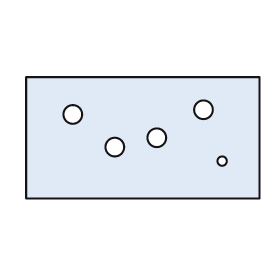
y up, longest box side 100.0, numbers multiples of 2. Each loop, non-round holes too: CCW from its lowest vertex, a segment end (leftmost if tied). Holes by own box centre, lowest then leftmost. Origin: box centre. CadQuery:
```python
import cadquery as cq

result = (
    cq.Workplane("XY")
    .moveTo(-50.0, -26.0)
    .lineTo(50.0, -26.0)
    .lineTo(50.0, 26.0)
    .lineTo(-50.0, 26.0)
    .close()
    .moveTo(34.0, -10.0)
    .circle(2.0)
    .moveTo(-12.0, -4.0)
    .circle(4.0)
    .moveTo(6.0, 0.0)
    .circle(4.0)
    .moveTo(-30.0, 10.0)
    .circle(4.0)
    .moveTo(26.0, 12.0)
    .circle(4.0)
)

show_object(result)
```